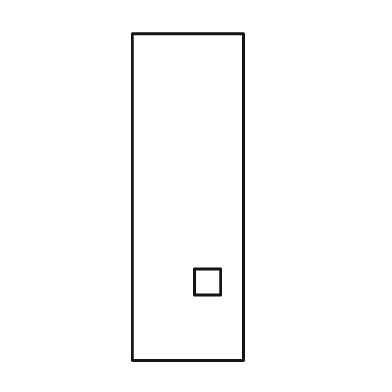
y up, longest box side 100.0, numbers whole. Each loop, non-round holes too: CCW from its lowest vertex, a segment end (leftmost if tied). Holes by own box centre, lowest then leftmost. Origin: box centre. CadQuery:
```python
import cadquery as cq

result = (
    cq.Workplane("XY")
    .moveTo(-17.0, -50.0)
    .lineTo(17.0, -50.0)
    .lineTo(17.0, 50.0)
    .lineTo(-17.0, 50.0)
    .close()
    .moveTo(2.0, -30.0)
    .lineTo(10.0, -30.0)
    .lineTo(10.0, -22.0)
    .lineTo(2.0, -22.0)
    .close()
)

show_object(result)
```